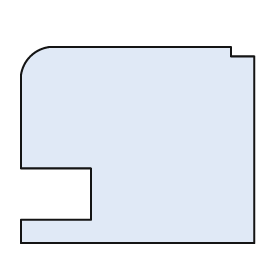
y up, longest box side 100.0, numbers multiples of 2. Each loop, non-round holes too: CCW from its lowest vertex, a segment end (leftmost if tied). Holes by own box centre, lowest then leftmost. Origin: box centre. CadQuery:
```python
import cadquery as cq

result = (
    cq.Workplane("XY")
    .moveTo(-50.0, -42.0)
    .lineTo(50.0, -42.0)
    .lineTo(50.0, 38.0)
    .lineTo(40.0, 38.0)
    .lineTo(40.0, 42.0)
    .lineTo(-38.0, 42.0)
    .threePointArc((-46.0, 38.0), (-50.0, 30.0))
    .lineTo(-50.0, -10.0)
    .lineTo(-20.0, -10.0)
    .lineTo(-20.0, -32.0)
    .lineTo(-50.0, -32.0)
    .close()
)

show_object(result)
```